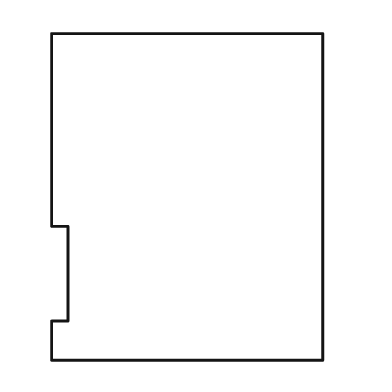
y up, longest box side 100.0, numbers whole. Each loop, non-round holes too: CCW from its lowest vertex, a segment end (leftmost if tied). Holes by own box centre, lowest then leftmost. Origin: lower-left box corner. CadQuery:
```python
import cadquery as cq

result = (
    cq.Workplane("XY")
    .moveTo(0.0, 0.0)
    .lineTo(83.0, 0.0)
    .lineTo(83.0, 100.0)
    .lineTo(0.0, 100.0)
    .lineTo(0.0, 41.0)
    .lineTo(5.0, 41.0)
    .lineTo(5.0, 12.0)
    .lineTo(0.0, 12.0)
    .close()
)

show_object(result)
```